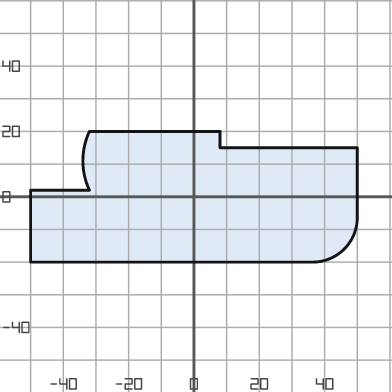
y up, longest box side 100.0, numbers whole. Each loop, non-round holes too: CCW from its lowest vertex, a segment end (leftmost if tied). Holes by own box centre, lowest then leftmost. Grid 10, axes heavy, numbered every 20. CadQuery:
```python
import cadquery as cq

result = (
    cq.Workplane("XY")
    .moveTo(-50.0, -20.0)
    .lineTo(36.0, -20.0)
    .threePointArc((46.0, -16.0), (50.0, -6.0))
    .lineTo(50.0, 15.0)
    .lineTo(8.0, 15.0)
    .lineTo(8.0, 20.0)
    .lineTo(-32.0, 20.0)
    .threePointArc((-34.0, 11.0), (-32.0, 2.0))
    .lineTo(-50.0, 2.0)
    .close()
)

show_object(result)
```